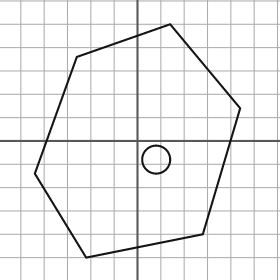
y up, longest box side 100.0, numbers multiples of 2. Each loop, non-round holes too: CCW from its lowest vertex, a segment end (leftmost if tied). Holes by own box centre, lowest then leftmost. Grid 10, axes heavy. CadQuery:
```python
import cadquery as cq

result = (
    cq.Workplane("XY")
    .moveTo(-22.0, -50.0)
    .lineTo(28.0, -40.0)
    .lineTo(44.0, 14.0)
    .lineTo(14.0, 50.0)
    .lineTo(-26.0, 36.0)
    .lineTo(-44.0, -14.0)
    .close()
    .moveTo(8.0, -8.0)
    .circle(6.0)
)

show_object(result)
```